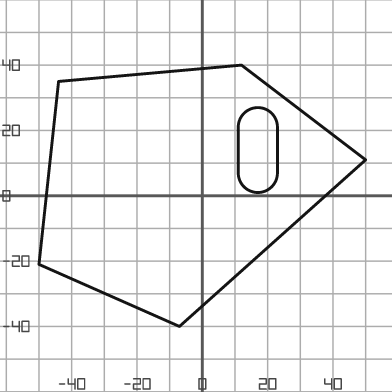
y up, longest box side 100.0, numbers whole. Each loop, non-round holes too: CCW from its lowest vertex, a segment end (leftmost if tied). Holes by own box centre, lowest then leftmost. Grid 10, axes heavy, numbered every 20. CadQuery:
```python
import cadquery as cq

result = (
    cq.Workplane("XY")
    .moveTo(-7.0, -40.0)
    .lineTo(50.0, 11.0)
    .lineTo(12.0, 40.0)
    .lineTo(-44.0, 35.0)
    .lineTo(-50.0, -21.0)
    .close()
    .moveTo(11.0, 7.0)
    .threePointArc((17.0, 1.0), (23.0, 7.0))
    .lineTo(23.0, 21.0)
    .threePointArc((17.0, 27.0), (11.0, 21.0))
    .close()
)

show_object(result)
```